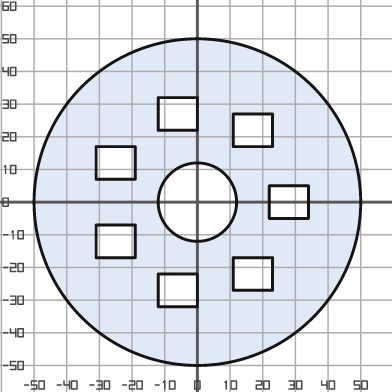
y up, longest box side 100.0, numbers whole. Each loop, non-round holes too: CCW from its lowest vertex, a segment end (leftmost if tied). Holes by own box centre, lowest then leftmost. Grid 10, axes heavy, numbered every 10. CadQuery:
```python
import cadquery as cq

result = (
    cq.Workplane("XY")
    .moveTo(0.0, 0.0)
    .circle(50.0)
    .moveTo(-12.0, -32.0)
    .lineTo(0.0, -32.0)
    .lineTo(0.0, -22.0)
    .lineTo(-12.0, -22.0)
    .close()
    .moveTo(11.0, -27.0)
    .lineTo(23.0, -27.0)
    .lineTo(23.0, -17.0)
    .lineTo(11.0, -17.0)
    .close()
    .moveTo(-31.0, -17.0)
    .lineTo(-19.0, -17.0)
    .lineTo(-19.0, -7.0)
    .lineTo(-31.0, -7.0)
    .close()
    .moveTo(0.0, 0.0)
    .circle(12.0)
    .moveTo(22.0, -5.0)
    .lineTo(34.0, -5.0)
    .lineTo(34.0, 5.0)
    .lineTo(22.0, 5.0)
    .close()
    .moveTo(-31.0, 7.0)
    .lineTo(-19.0, 7.0)
    .lineTo(-19.0, 17.0)
    .lineTo(-31.0, 17.0)
    .close()
    .moveTo(11.0, 17.0)
    .lineTo(23.0, 17.0)
    .lineTo(23.0, 27.0)
    .lineTo(11.0, 27.0)
    .close()
    .moveTo(-12.0, 22.0)
    .lineTo(0.0, 22.0)
    .lineTo(0.0, 32.0)
    .lineTo(-12.0, 32.0)
    .close()
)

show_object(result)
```